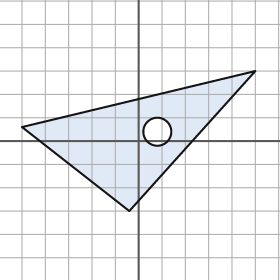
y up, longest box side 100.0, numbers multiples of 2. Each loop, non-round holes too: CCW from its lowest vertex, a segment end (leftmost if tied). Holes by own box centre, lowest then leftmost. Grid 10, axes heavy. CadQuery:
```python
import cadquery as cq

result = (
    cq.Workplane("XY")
    .moveTo(-4.0, -30.0)
    .lineTo(50.0, 30.0)
    .lineTo(-50.0, 6.0)
    .close()
    .moveTo(8.0, 4.0)
    .circle(6.0)
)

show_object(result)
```